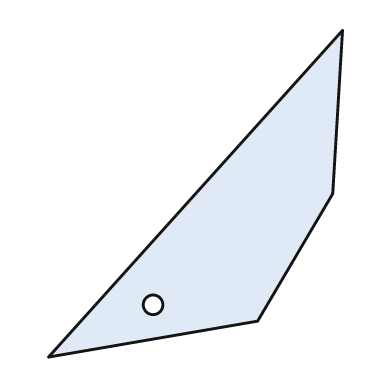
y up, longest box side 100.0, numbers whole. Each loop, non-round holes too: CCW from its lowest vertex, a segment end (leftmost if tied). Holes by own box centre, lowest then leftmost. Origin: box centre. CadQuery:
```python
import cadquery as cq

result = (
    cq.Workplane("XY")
    .moveTo(-45.0, -50.0)
    .lineTo(19.0, -39.0)
    .lineTo(42.0, 0.0)
    .lineTo(45.0, 50.0)
    .close()
    .moveTo(-13.0, -34.0)
    .circle(3.0)
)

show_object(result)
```